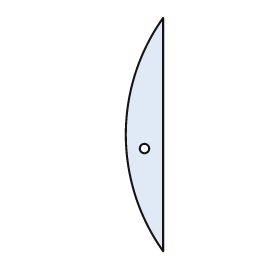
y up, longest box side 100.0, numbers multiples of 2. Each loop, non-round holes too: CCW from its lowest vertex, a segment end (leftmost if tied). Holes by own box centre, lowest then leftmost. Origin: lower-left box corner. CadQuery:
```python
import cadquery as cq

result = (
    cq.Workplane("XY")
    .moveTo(16.0, 0.0)
    .lineTo(16.0, 100.0)
    .threePointArc((0.0, 50.0), (16.0, 0.0))
    .close()
    .moveTo(8.0, 44.0)
    .circle(2.0)
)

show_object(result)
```